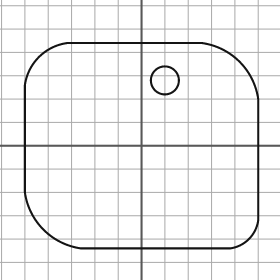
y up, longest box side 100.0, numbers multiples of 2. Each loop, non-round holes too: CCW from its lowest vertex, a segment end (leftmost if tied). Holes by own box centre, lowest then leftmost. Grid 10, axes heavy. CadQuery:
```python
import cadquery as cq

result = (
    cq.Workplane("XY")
    .moveTo(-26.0, -44.0)
    .lineTo(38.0, -44.0)
    .threePointArc((46.0, -40.0), (50.0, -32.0))
    .lineTo(50.0, 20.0)
    .threePointArc((42.0, 36.0), (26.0, 44.0))
    .lineTo(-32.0, 44.0)
    .threePointArc((-44.0, 38.0), (-50.0, 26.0))
    .lineTo(-50.0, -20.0)
    .threePointArc((-42.0, -36.0), (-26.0, -44.0))
    .close()
    .moveTo(10.0, 28.0)
    .circle(6.0)
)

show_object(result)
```